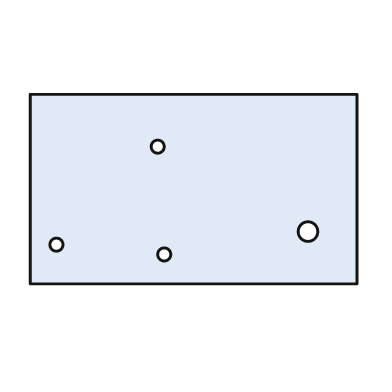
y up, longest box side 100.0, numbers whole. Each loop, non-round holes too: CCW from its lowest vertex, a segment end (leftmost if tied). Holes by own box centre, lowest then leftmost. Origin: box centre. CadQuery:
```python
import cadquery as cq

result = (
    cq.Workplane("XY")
    .moveTo(-50.0, -29.0)
    .lineTo(50.0, -29.0)
    .lineTo(50.0, 29.0)
    .lineTo(-50.0, 29.0)
    .close()
    .moveTo(-9.0, -20.0)
    .circle(2.0)
    .moveTo(-42.0, -17.0)
    .circle(2.0)
    .moveTo(35.0, -13.0)
    .circle(3.0)
    .moveTo(-11.0, 13.0)
    .circle(2.0)
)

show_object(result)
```